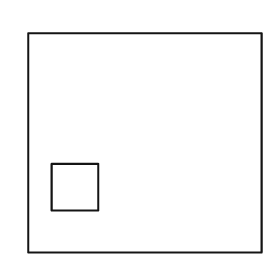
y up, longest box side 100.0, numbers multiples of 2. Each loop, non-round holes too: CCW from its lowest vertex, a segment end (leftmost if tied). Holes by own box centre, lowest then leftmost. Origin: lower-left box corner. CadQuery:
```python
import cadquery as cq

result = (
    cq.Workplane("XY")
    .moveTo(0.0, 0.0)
    .lineTo(100.0, 0.0)
    .lineTo(100.0, 94.0)
    .lineTo(0.0, 94.0)
    .close()
    .moveTo(10.0, 18.0)
    .lineTo(30.0, 18.0)
    .lineTo(30.0, 38.0)
    .lineTo(10.0, 38.0)
    .close()
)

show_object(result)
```